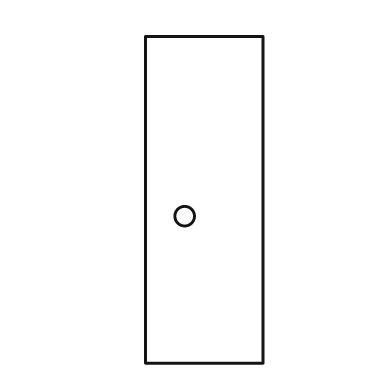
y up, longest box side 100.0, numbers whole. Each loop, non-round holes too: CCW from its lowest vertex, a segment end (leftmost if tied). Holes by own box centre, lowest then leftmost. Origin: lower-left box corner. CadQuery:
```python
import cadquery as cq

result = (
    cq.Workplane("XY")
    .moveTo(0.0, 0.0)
    .lineTo(36.0, 0.0)
    .lineTo(36.0, 100.0)
    .lineTo(0.0, 100.0)
    .close()
    .moveTo(12.0, 45.0)
    .circle(3.0)
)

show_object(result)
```